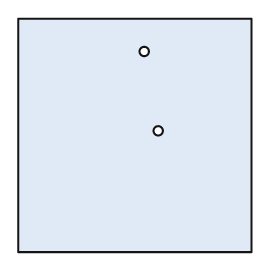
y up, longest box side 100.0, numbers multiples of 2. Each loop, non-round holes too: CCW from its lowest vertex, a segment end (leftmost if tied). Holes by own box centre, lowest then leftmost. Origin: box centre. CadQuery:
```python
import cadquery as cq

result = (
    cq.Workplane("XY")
    .moveTo(-50.0, -50.0)
    .lineTo(50.0, -50.0)
    .lineTo(50.0, 50.0)
    .lineTo(-50.0, 50.0)
    .close()
    .moveTo(10.0, 2.0)
    .circle(2.0)
    .moveTo(4.0, 36.0)
    .circle(2.0)
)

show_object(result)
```